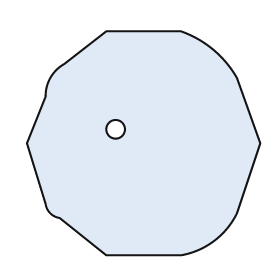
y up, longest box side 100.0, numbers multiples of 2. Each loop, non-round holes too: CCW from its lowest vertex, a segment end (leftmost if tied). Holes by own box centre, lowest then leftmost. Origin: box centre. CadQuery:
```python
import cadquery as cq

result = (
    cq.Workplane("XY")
    .moveTo(-16.0, -48.0)
    .lineTo(16.0, -48.0)
    .threePointArc((30.0, -42.0), (40.0, -30.0))
    .lineTo(50.0, 0.0)
    .lineTo(40.0, 28.0)
    .threePointArc((30.0, 40.0), (16.0, 48.0))
    .lineTo(-16.0, 48.0)
    .lineTo(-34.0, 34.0)
    .threePointArc((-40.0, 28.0), (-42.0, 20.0))
    .lineTo(-50.0, 0.0)
    .lineTo(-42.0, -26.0)
    .threePointArc((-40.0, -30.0), (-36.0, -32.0))
    .close()
    .moveTo(-12.0, 6.0)
    .circle(4.0)
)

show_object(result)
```